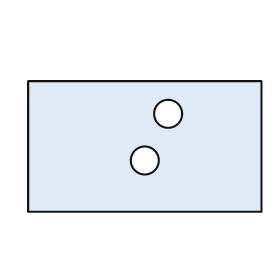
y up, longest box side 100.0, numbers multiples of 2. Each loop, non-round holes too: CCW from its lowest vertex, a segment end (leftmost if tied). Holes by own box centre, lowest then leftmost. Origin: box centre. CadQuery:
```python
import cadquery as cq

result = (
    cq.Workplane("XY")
    .moveTo(-50.0, -28.0)
    .lineTo(50.0, -28.0)
    .lineTo(50.0, 28.0)
    .lineTo(-50.0, 28.0)
    .close()
    .moveTo(0.0, -6.0)
    .circle(6.0)
    .moveTo(10.0, 14.0)
    .circle(6.0)
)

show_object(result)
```